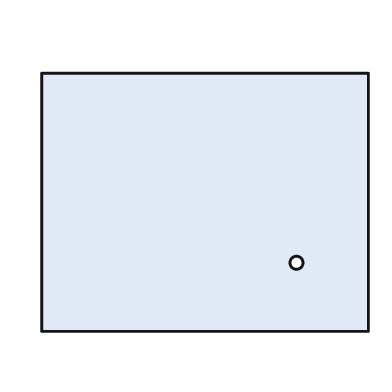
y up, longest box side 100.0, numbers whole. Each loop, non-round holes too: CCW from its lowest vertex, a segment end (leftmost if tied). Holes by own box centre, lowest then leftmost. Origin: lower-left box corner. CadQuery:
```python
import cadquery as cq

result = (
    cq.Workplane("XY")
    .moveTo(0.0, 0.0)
    .lineTo(100.0, 0.0)
    .lineTo(100.0, 79.0)
    .lineTo(0.0, 79.0)
    .close()
    .moveTo(78.0, 21.0)
    .circle(2.0)
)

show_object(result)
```